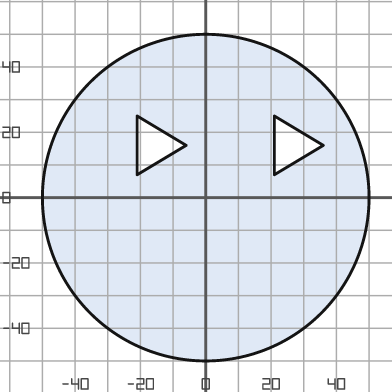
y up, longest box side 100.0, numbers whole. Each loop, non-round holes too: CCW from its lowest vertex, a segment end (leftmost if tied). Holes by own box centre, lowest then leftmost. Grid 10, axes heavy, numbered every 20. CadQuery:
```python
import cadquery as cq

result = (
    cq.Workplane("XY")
    .moveTo(0.0, 0.0)
    .circle(50.0)
    .moveTo(-21.0, 7.0)
    .lineTo(-6.0, 16.0)
    .lineTo(-21.0, 25.0)
    .close()
    .moveTo(21.0, 7.0)
    .lineTo(36.0, 16.0)
    .lineTo(21.0, 25.0)
    .close()
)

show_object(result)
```